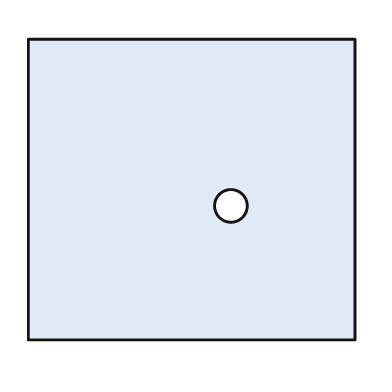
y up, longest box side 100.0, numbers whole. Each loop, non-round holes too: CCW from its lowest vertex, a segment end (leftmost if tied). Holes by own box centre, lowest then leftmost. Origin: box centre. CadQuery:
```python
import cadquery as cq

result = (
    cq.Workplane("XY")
    .moveTo(-50.0, -46.0)
    .lineTo(50.0, -46.0)
    .lineTo(50.0, 46.0)
    .lineTo(-50.0, 46.0)
    .close()
    .moveTo(12.0, -5.0)
    .circle(5.0)
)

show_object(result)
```